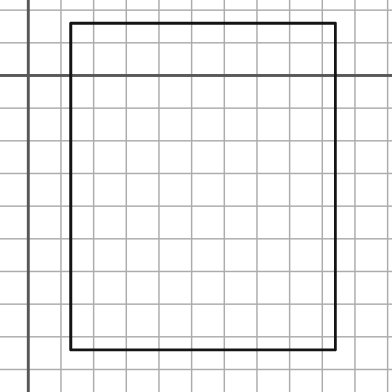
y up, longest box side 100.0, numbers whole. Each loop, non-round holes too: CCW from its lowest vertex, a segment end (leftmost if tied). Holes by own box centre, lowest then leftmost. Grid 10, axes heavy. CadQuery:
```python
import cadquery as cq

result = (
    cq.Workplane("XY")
    .moveTo(13.0, -84.0)
    .lineTo(94.0, -84.0)
    .lineTo(94.0, 16.0)
    .lineTo(13.0, 16.0)
    .close()
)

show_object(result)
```